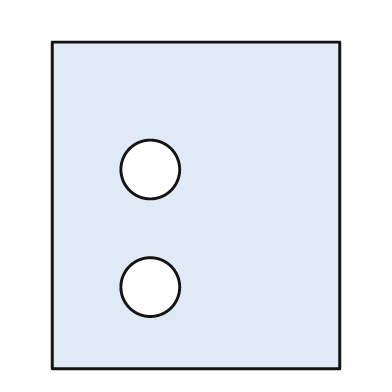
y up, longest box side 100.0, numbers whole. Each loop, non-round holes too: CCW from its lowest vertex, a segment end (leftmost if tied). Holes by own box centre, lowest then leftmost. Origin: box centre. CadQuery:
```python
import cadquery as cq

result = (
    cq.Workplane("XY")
    .moveTo(-44.0, -50.0)
    .lineTo(44.0, -50.0)
    .lineTo(44.0, 50.0)
    .lineTo(-44.0, 50.0)
    .close()
    .moveTo(-14.0, -25.0)
    .circle(9.0)
    .moveTo(-14.0, 11.0)
    .circle(9.0)
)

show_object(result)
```